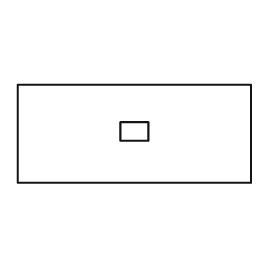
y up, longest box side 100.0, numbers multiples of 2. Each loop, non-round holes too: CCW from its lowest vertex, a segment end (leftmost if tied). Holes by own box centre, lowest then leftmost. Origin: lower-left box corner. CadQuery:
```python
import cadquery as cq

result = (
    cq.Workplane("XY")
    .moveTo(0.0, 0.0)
    .lineTo(100.0, 0.0)
    .lineTo(100.0, 42.0)
    .lineTo(0.0, 42.0)
    .close()
    .moveTo(44.0, 18.0)
    .lineTo(56.0, 18.0)
    .lineTo(56.0, 26.0)
    .lineTo(44.0, 26.0)
    .close()
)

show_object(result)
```